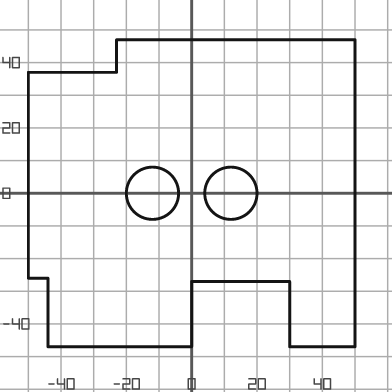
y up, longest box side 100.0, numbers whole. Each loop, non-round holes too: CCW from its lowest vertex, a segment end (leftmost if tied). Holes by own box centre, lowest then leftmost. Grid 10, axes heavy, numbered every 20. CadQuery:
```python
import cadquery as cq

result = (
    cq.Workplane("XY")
    .moveTo(-44.0, -47.0)
    .lineTo(0.0, -47.0)
    .lineTo(0.0, -27.0)
    .lineTo(30.0, -27.0)
    .lineTo(30.0, -47.0)
    .lineTo(50.0, -47.0)
    .lineTo(50.0, 47.0)
    .lineTo(-23.0, 47.0)
    .lineTo(-23.0, 37.0)
    .lineTo(-50.0, 37.0)
    .lineTo(-50.0, -26.0)
    .lineTo(-44.0, -26.0)
    .close()
    .moveTo(-12.0, 0.0)
    .circle(8.0)
    .moveTo(12.0, 0.0)
    .circle(8.0)
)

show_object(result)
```